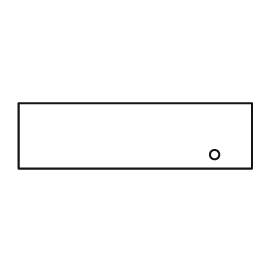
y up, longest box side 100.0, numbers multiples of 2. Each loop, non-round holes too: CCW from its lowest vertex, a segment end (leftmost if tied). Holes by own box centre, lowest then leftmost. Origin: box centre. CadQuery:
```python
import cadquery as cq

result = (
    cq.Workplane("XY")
    .moveTo(-50.0, -14.0)
    .lineTo(50.0, -14.0)
    .lineTo(50.0, 14.0)
    .lineTo(-50.0, 14.0)
    .close()
    .moveTo(34.0, -8.0)
    .circle(2.0)
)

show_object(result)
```